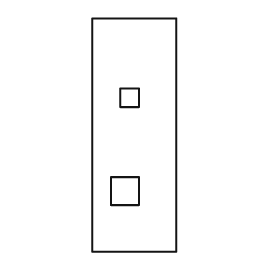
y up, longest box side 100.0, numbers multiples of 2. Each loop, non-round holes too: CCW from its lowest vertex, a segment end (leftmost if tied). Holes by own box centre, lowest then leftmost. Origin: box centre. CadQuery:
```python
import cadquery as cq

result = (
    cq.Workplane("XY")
    .moveTo(-18.0, -50.0)
    .lineTo(18.0, -50.0)
    .lineTo(18.0, 50.0)
    .lineTo(-18.0, 50.0)
    .close()
    .moveTo(-10.0, -30.0)
    .lineTo(2.0, -30.0)
    .lineTo(2.0, -18.0)
    .lineTo(-10.0, -18.0)
    .close()
    .moveTo(-6.0, 12.0)
    .lineTo(2.0, 12.0)
    .lineTo(2.0, 20.0)
    .lineTo(-6.0, 20.0)
    .close()
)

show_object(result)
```